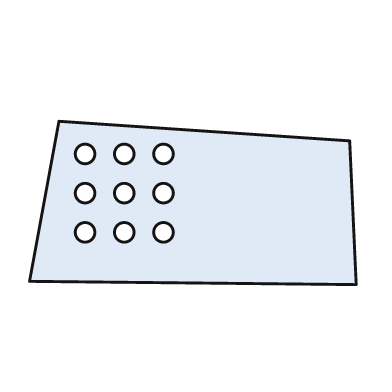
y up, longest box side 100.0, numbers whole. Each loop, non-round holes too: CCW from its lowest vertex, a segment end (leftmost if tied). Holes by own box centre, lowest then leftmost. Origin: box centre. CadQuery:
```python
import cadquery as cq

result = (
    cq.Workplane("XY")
    .moveTo(50.0, -25.0)
    .lineTo(48.0, 19.0)
    .lineTo(-41.0, 25.0)
    .lineTo(-50.0, -24.0)
    .close()
    .moveTo(-33.0, -9.0)
    .circle(3.0)
    .moveTo(-21.0, -9.0)
    .circle(3.0)
    .moveTo(-9.0, -9.0)
    .circle(3.0)
    .moveTo(-33.0, 3.0)
    .circle(3.0)
    .moveTo(-21.0, 3.0)
    .circle(3.0)
    .moveTo(-9.0, 3.0)
    .circle(3.0)
    .moveTo(-33.0, 15.0)
    .circle(3.0)
    .moveTo(-21.0, 15.0)
    .circle(3.0)
    .moveTo(-9.0, 15.0)
    .circle(3.0)
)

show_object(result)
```